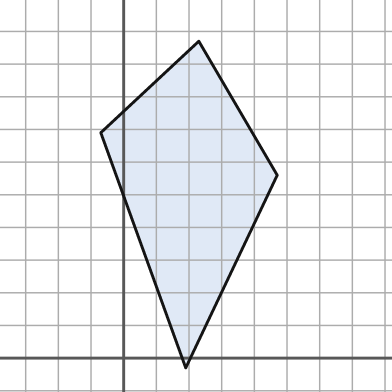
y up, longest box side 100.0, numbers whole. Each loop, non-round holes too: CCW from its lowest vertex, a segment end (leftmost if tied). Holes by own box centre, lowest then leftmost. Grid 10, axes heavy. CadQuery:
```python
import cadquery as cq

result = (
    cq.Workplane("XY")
    .moveTo(19.0, -3.0)
    .lineTo(47.0, 56.0)
    .lineTo(23.0, 97.0)
    .lineTo(-7.0, 69.0)
    .close()
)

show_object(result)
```